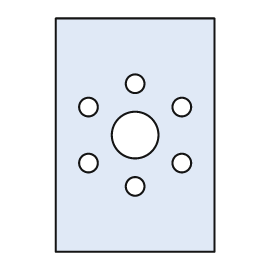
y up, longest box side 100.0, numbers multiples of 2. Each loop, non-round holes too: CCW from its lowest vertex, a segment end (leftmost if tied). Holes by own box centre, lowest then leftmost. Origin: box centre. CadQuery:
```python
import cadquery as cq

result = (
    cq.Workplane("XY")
    .moveTo(-34.0, -50.0)
    .lineTo(34.0, -50.0)
    .lineTo(34.0, 50.0)
    .lineTo(-34.0, 50.0)
    .close()
    .moveTo(0.0, -22.0)
    .circle(4.0)
    .moveTo(-20.0, -12.0)
    .circle(4.0)
    .moveTo(20.0, -12.0)
    .circle(4.0)
    .moveTo(0.0, 0.0)
    .circle(10.0)
    .moveTo(-20.0, 12.0)
    .circle(4.0)
    .moveTo(20.0, 12.0)
    .circle(4.0)
    .moveTo(0.0, 22.0)
    .circle(4.0)
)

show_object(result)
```